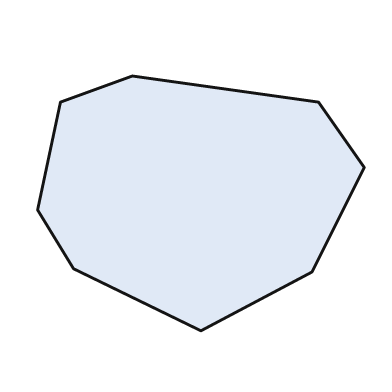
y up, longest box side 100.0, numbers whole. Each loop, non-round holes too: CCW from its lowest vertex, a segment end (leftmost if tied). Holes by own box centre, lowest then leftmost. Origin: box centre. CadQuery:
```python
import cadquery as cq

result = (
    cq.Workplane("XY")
    .moveTo(0.0, -39.0)
    .lineTo(34.0, -21.0)
    .lineTo(50.0, 11.0)
    .lineTo(36.0, 31.0)
    .lineTo(-21.0, 39.0)
    .lineTo(-43.0, 31.0)
    .lineTo(-50.0, -2.0)
    .lineTo(-39.0, -20.0)
    .close()
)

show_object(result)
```